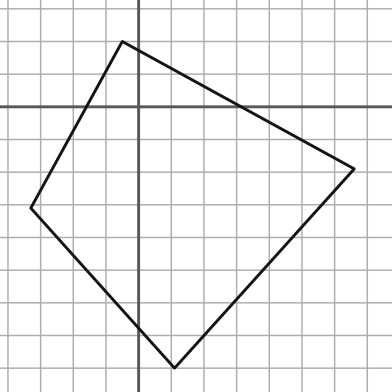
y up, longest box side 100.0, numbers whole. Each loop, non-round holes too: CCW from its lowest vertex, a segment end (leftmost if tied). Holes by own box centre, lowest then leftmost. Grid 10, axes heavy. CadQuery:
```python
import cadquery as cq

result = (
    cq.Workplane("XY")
    .moveTo(11.0, -80.0)
    .lineTo(66.0, -19.0)
    .lineTo(-5.0, 20.0)
    .lineTo(-33.0, -31.0)
    .close()
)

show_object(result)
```